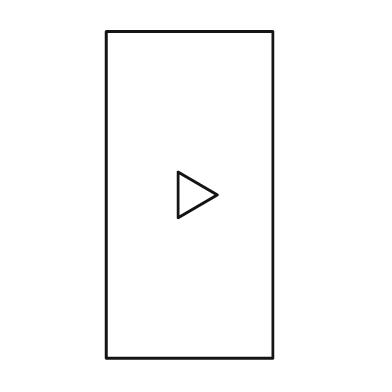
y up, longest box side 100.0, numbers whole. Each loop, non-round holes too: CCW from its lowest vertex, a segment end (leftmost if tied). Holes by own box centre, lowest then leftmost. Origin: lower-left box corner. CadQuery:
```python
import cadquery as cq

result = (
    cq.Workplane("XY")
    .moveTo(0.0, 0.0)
    .lineTo(51.0, 0.0)
    .lineTo(51.0, 100.0)
    .lineTo(0.0, 100.0)
    .close()
    .moveTo(22.0, 43.0)
    .lineTo(34.0, 50.0)
    .lineTo(22.0, 57.0)
    .close()
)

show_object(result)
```